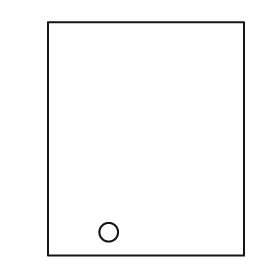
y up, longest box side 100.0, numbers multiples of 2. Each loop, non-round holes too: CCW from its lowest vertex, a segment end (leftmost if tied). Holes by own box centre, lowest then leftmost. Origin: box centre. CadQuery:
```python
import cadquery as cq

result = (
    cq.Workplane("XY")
    .moveTo(-42.0, -50.0)
    .lineTo(42.0, -50.0)
    .lineTo(42.0, 50.0)
    .lineTo(-42.0, 50.0)
    .close()
    .moveTo(-16.0, -40.0)
    .circle(4.0)
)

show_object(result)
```